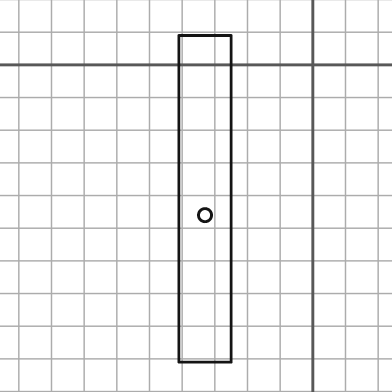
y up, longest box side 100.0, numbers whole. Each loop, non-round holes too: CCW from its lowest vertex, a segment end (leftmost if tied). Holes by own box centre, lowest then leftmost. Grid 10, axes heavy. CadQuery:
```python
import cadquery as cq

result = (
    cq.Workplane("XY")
    .moveTo(-41.0, -91.0)
    .lineTo(-25.0, -91.0)
    .lineTo(-25.0, 9.0)
    .lineTo(-41.0, 9.0)
    .close()
    .moveTo(-33.0, -46.0)
    .circle(2.0)
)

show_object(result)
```